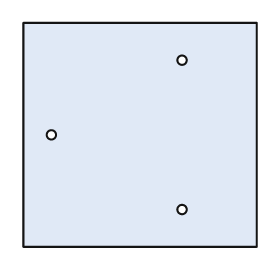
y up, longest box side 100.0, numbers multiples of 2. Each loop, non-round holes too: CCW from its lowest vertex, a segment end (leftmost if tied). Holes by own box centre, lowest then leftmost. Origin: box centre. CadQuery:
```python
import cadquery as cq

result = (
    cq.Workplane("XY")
    .moveTo(-50.0, -48.0)
    .lineTo(50.0, -48.0)
    .lineTo(50.0, 48.0)
    .lineTo(-50.0, 48.0)
    .close()
    .moveTo(18.0, -32.0)
    .circle(2.0)
    .moveTo(-38.0, 0.0)
    .circle(2.0)
    .moveTo(18.0, 32.0)
    .circle(2.0)
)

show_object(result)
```